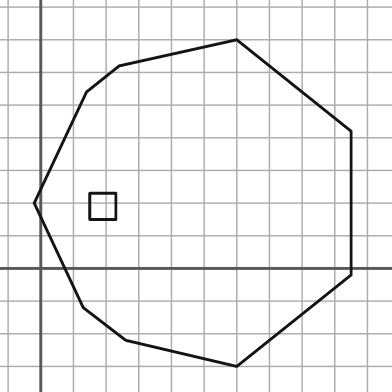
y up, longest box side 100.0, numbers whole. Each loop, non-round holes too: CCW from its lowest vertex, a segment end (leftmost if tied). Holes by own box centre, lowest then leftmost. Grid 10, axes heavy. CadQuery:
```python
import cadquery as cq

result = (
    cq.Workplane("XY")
    .moveTo(60.0, -30.0)
    .lineTo(95.0, -2.0)
    .lineTo(95.0, 42.0)
    .lineTo(60.0, 70.0)
    .lineTo(24.0, 62.0)
    .lineTo(14.0, 54.0)
    .lineTo(-2.0, 20.0)
    .lineTo(13.0, -12.0)
    .lineTo(26.0, -22.0)
    .close()
    .moveTo(15.0, 15.0)
    .lineTo(23.0, 15.0)
    .lineTo(23.0, 23.0)
    .lineTo(15.0, 23.0)
    .close()
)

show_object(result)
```